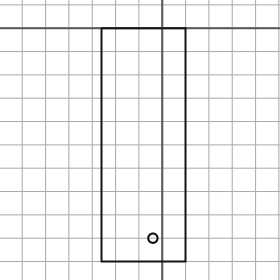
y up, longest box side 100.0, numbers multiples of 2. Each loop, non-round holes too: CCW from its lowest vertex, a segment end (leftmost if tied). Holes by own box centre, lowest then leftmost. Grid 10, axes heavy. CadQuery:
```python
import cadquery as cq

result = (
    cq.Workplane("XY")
    .moveTo(-26.0, -100.0)
    .lineTo(10.0, -100.0)
    .lineTo(10.0, 0.0)
    .lineTo(-26.0, 0.0)
    .close()
    .moveTo(-4.0, -90.0)
    .circle(2.0)
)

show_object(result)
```